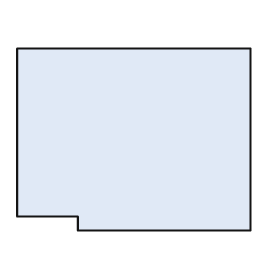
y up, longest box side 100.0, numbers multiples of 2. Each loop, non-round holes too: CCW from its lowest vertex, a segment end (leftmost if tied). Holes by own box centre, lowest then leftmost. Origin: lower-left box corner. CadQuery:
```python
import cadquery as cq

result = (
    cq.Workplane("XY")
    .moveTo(26.0, 0.0)
    .lineTo(100.0, 0.0)
    .lineTo(100.0, 78.0)
    .lineTo(0.0, 78.0)
    .lineTo(0.0, 6.0)
    .lineTo(26.0, 6.0)
    .close()
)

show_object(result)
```